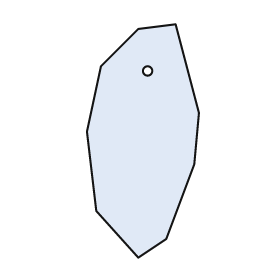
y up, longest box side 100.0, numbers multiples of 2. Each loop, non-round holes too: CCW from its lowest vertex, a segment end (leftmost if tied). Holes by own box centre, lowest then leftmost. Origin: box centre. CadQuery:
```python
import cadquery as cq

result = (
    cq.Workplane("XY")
    .moveTo(-2.0, -50.0)
    .lineTo(10.0, -42.0)
    .lineTo(22.0, -10.0)
    .lineTo(24.0, 12.0)
    .lineTo(14.0, 50.0)
    .lineTo(-2.0, 48.0)
    .lineTo(-18.0, 32.0)
    .lineTo(-24.0, 4.0)
    .lineTo(-20.0, -30.0)
    .close()
    .moveTo(2.0, 30.0)
    .circle(2.0)
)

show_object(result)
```